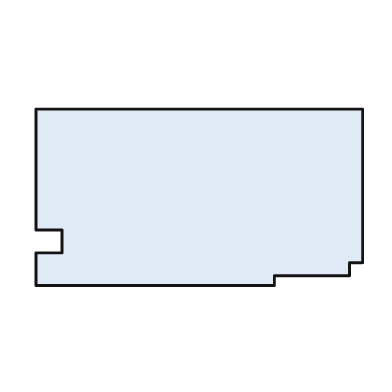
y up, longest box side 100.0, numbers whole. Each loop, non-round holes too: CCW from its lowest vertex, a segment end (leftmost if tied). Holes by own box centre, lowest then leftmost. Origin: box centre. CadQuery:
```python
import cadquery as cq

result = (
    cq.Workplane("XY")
    .moveTo(-50.0, -27.0)
    .lineTo(23.0, -27.0)
    .lineTo(23.0, -24.0)
    .lineTo(46.0, -24.0)
    .lineTo(46.0, -20.0)
    .lineTo(50.0, -20.0)
    .lineTo(50.0, 27.0)
    .lineTo(-50.0, 27.0)
    .lineTo(-50.0, -10.0)
    .lineTo(-42.0, -10.0)
    .lineTo(-42.0, -17.0)
    .lineTo(-50.0, -17.0)
    .close()
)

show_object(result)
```